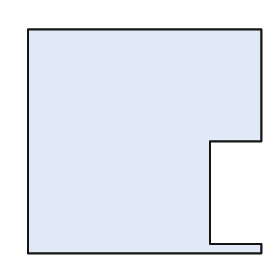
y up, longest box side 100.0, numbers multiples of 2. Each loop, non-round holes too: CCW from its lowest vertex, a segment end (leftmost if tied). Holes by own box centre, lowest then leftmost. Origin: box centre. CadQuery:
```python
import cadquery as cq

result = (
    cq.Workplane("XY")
    .moveTo(-50.0, -48.0)
    .lineTo(50.0, -48.0)
    .lineTo(50.0, -44.0)
    .lineTo(28.0, -44.0)
    .lineTo(28.0, 0.0)
    .lineTo(50.0, 0.0)
    .lineTo(50.0, 48.0)
    .lineTo(-50.0, 48.0)
    .close()
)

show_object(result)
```